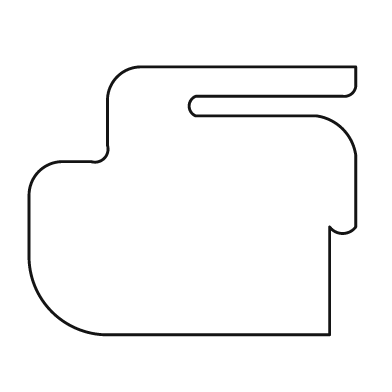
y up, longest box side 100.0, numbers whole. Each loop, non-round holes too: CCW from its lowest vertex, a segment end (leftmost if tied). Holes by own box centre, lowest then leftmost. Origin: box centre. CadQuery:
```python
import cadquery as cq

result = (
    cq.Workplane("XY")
    .moveTo(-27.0, -41.0)
    .lineTo(42.0, -41.0)
    .lineTo(42.0, -8.0)
    .threePointArc((46.0, -10.0), (50.0, -8.0))
    .lineTo(50.0, 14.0)
    .threePointArc((46.0, 22.0), (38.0, 26.0))
    .lineTo(1.0, 26.0)
    .threePointArc((-1.0, 29.0), (1.0, 32.0))
    .lineTo(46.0, 32.0)
    .threePointArc((49.0, 33.0), (50.0, 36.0))
    .lineTo(50.0, 41.0)
    .lineTo(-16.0, 41.0)
    .threePointArc((-23.0, 38.0), (-26.0, 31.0))
    .lineTo(-26.0, 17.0)
    .threePointArc((-27.0, 13.0), (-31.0, 12.0))
    .lineTo(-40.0, 12.0)
    .threePointArc((-47.0, 9.0), (-50.0, 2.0))
    .lineTo(-50.0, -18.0)
    .threePointArc((-43.0, -34.0), (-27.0, -41.0))
    .close()
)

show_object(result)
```